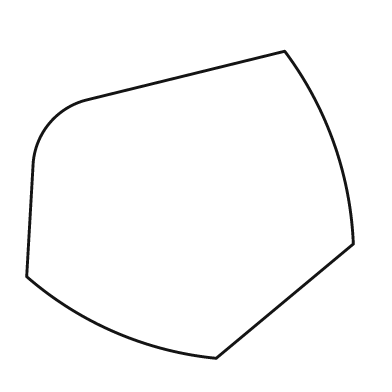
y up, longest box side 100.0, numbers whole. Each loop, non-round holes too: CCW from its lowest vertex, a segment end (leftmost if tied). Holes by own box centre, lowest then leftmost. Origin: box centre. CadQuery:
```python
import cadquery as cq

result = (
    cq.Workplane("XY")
    .moveTo(8.0, -47.0)
    .lineTo(50.0, -12.0)
    .threePointArc((44.0, 19.0), (29.0, 47.0))
    .lineTo(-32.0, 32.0)
    .threePointArc((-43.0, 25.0), (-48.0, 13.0))
    .lineTo(-50.0, -22.0)
    .threePointArc((-23.0, -39.0), (8.0, -47.0))
    .close()
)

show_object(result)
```